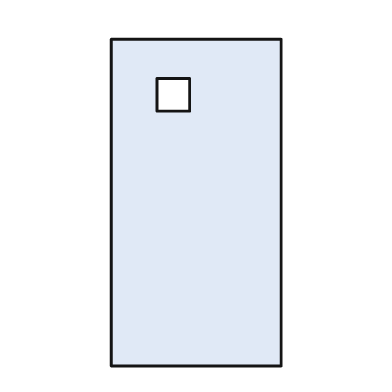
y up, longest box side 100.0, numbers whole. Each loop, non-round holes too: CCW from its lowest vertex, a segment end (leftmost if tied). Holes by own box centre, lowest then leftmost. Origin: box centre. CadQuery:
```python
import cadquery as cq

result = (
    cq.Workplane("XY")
    .moveTo(-26.0, -50.0)
    .lineTo(26.0, -50.0)
    .lineTo(26.0, 50.0)
    .lineTo(-26.0, 50.0)
    .close()
    .moveTo(-12.0, 28.0)
    .lineTo(-2.0, 28.0)
    .lineTo(-2.0, 38.0)
    .lineTo(-12.0, 38.0)
    .close()
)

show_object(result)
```